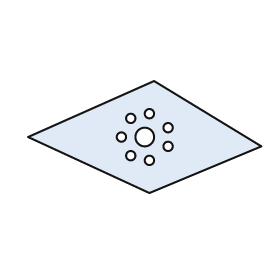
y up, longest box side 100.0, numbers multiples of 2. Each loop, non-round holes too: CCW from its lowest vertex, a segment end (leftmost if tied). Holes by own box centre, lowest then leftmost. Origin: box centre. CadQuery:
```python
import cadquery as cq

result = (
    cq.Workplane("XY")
    .moveTo(2.0, -24.0)
    .lineTo(50.0, -4.0)
    .lineTo(4.0, 24.0)
    .lineTo(-50.0, 0.0)
    .close()
    .moveTo(2.0, -10.0)
    .circle(2.0)
    .moveTo(-6.0, -8.0)
    .circle(2.0)
    .moveTo(10.0, -4.0)
    .circle(2.0)
    .moveTo(-10.0, 0.0)
    .circle(2.0)
    .moveTo(0.0, 0.0)
    .circle(4.0)
    .moveTo(10.0, 4.0)
    .circle(2.0)
    .moveTo(-6.0, 8.0)
    .circle(2.0)
    .moveTo(2.0, 10.0)
    .circle(2.0)
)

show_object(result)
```